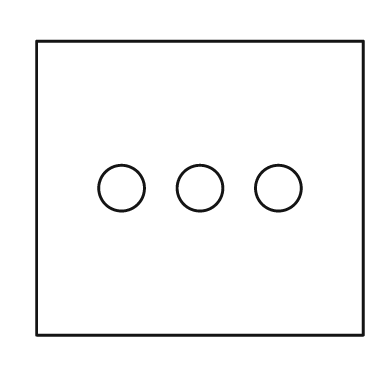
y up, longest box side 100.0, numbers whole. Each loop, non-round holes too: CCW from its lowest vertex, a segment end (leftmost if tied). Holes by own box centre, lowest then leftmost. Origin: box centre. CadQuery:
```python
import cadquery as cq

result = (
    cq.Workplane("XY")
    .moveTo(-50.0, -45.0)
    .lineTo(50.0, -45.0)
    .lineTo(50.0, 45.0)
    .lineTo(-50.0, 45.0)
    .close()
    .moveTo(-24.0, 0.0)
    .circle(7.0)
    .moveTo(0.0, 0.0)
    .circle(7.0)
    .moveTo(24.0, 0.0)
    .circle(7.0)
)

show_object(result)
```